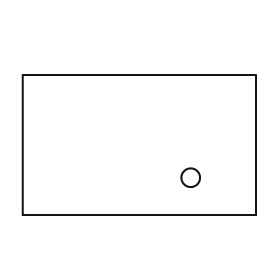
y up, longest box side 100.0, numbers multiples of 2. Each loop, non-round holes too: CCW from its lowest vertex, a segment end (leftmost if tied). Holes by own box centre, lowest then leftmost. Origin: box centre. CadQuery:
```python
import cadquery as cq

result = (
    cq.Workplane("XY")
    .moveTo(-50.0, -30.0)
    .lineTo(50.0, -30.0)
    .lineTo(50.0, 30.0)
    .lineTo(-50.0, 30.0)
    .close()
    .moveTo(22.0, -14.0)
    .circle(4.0)
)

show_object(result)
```